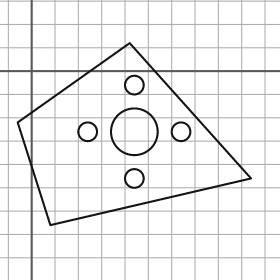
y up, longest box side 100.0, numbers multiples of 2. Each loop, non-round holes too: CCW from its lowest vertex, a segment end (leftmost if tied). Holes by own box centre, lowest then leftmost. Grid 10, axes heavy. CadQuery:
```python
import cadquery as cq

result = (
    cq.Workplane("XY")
    .moveTo(8.0, -66.0)
    .lineTo(94.0, -46.0)
    .lineTo(42.0, 12.0)
    .lineTo(-6.0, -22.0)
    .close()
    .moveTo(44.0, -46.0)
    .circle(4.0)
    .moveTo(24.0, -26.0)
    .circle(4.0)
    .moveTo(44.0, -26.0)
    .circle(10.0)
    .moveTo(64.0, -26.0)
    .circle(4.0)
    .moveTo(44.0, -6.0)
    .circle(4.0)
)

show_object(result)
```